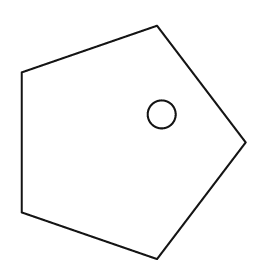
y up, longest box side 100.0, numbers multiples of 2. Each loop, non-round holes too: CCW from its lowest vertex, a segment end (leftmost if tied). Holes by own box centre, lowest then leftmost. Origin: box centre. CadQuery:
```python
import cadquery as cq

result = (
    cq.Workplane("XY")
    .moveTo(10.0, -50.0)
    .lineTo(48.0, 0.0)
    .lineTo(10.0, 50.0)
    .lineTo(-48.0, 30.0)
    .lineTo(-48.0, -30.0)
    .close()
    .moveTo(12.0, 12.0)
    .circle(6.0)
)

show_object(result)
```